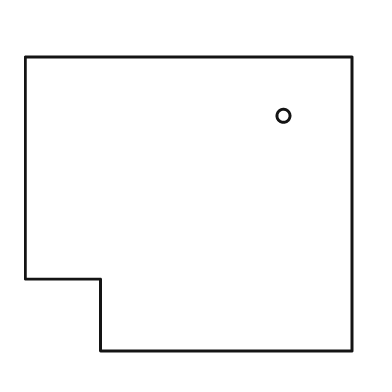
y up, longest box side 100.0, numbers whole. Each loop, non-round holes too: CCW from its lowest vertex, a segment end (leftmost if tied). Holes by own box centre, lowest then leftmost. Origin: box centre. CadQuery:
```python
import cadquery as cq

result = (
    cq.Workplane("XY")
    .moveTo(-27.0, -45.0)
    .lineTo(50.0, -45.0)
    .lineTo(50.0, 45.0)
    .lineTo(-50.0, 45.0)
    .lineTo(-50.0, -23.0)
    .lineTo(-27.0, -23.0)
    .close()
    .moveTo(29.0, 27.0)
    .circle(2.0)
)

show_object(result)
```